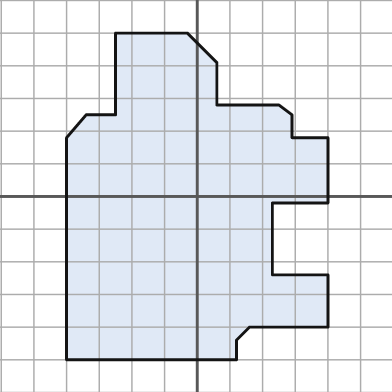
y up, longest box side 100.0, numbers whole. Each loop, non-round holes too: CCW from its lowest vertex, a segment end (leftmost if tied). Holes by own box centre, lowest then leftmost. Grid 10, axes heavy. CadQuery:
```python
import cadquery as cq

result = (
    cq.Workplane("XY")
    .moveTo(-40.0, -50.0)
    .lineTo(12.0, -50.0)
    .lineTo(12.0, -44.0)
    .lineTo(16.0, -40.0)
    .lineTo(40.0, -40.0)
    .lineTo(40.0, -24.0)
    .lineTo(23.0, -24.0)
    .lineTo(23.0, -2.0)
    .lineTo(40.0, -2.0)
    .lineTo(40.0, 18.0)
    .lineTo(29.0, 18.0)
    .lineTo(29.0, 25.0)
    .lineTo(25.0, 28.0)
    .lineTo(6.0, 28.0)
    .lineTo(6.0, 41.0)
    .lineTo(-3.0, 50.0)
    .lineTo(-25.0, 50.0)
    .lineTo(-25.0, 25.0)
    .lineTo(-34.0, 25.0)
    .lineTo(-40.0, 18.0)
    .close()
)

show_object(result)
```